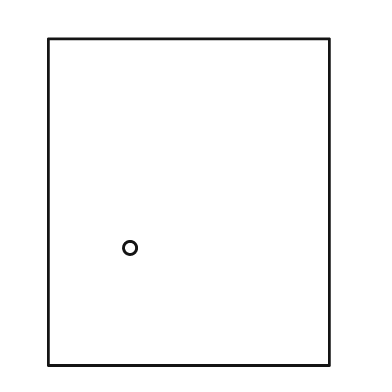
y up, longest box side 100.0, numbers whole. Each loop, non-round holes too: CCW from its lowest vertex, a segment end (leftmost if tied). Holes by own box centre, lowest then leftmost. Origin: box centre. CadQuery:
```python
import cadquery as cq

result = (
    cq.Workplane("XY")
    .moveTo(-43.0, -50.0)
    .lineTo(43.0, -50.0)
    .lineTo(43.0, 50.0)
    .lineTo(-43.0, 50.0)
    .close()
    .moveTo(-18.0, -14.0)
    .circle(2.0)
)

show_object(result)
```